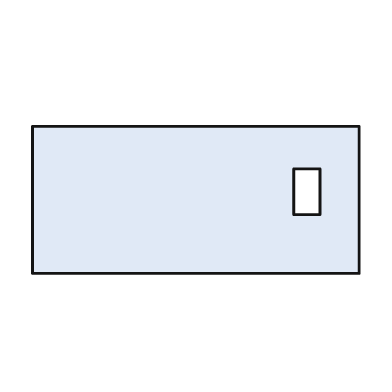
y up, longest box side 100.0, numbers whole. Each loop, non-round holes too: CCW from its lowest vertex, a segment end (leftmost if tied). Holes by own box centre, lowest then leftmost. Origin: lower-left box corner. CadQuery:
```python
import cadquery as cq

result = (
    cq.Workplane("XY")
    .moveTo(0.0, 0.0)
    .lineTo(100.0, 0.0)
    .lineTo(100.0, 45.0)
    .lineTo(0.0, 45.0)
    .close()
    .moveTo(80.0, 18.0)
    .lineTo(88.0, 18.0)
    .lineTo(88.0, 32.0)
    .lineTo(80.0, 32.0)
    .close()
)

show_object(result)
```